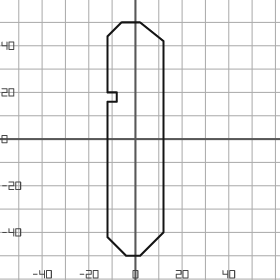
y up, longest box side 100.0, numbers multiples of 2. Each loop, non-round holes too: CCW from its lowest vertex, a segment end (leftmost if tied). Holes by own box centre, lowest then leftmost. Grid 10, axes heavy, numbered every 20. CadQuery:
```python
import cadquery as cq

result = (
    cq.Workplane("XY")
    .moveTo(-4.0, -50.0)
    .lineTo(2.0, -50.0)
    .lineTo(12.0, -40.0)
    .lineTo(12.0, 42.0)
    .lineTo(2.0, 50.0)
    .lineTo(-6.0, 50.0)
    .lineTo(-12.0, 44.0)
    .lineTo(-12.0, 20.0)
    .lineTo(-8.0, 20.0)
    .lineTo(-8.0, 16.0)
    .lineTo(-12.0, 16.0)
    .lineTo(-12.0, -42.0)
    .close()
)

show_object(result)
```